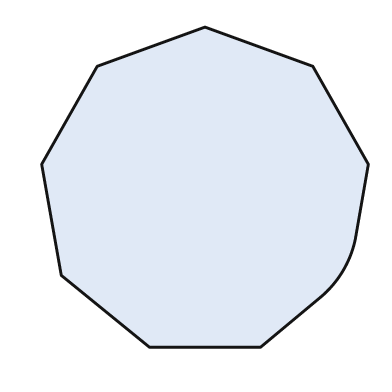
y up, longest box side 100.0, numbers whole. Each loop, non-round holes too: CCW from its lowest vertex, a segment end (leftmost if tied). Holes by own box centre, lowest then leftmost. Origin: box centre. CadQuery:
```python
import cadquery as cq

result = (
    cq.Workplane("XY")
    .moveTo(-17.0, -49.0)
    .lineTo(17.0, -49.0)
    .lineTo(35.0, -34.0)
    .threePointArc((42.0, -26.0), (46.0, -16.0))
    .lineTo(50.0, 7.0)
    .lineTo(33.0, 37.0)
    .lineTo(0.0, 49.0)
    .lineTo(-33.0, 37.0)
    .lineTo(-50.0, 7.0)
    .lineTo(-44.0, -27.0)
    .close()
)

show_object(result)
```